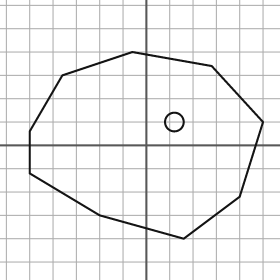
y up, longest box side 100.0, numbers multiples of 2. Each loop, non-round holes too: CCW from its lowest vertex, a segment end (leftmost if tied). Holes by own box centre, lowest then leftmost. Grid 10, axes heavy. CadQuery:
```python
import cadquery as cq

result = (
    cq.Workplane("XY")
    .moveTo(16.0, -40.0)
    .lineTo(40.0, -22.0)
    .lineTo(50.0, 10.0)
    .lineTo(28.0, 34.0)
    .lineTo(-6.0, 40.0)
    .lineTo(-36.0, 30.0)
    .lineTo(-50.0, 6.0)
    .lineTo(-50.0, -12.0)
    .lineTo(-20.0, -30.0)
    .close()
    .moveTo(12.0, 10.0)
    .circle(4.0)
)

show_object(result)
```